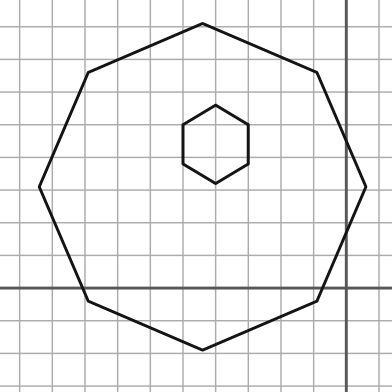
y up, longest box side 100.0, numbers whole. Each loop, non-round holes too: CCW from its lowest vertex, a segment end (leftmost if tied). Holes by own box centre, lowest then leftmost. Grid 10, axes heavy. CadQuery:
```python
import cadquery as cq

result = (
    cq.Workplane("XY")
    .moveTo(-44.0, -19.0)
    .lineTo(-9.0, -4.0)
    .lineTo(6.0, 31.0)
    .lineTo(-9.0, 66.0)
    .lineTo(-44.0, 81.0)
    .lineTo(-79.0, 66.0)
    .lineTo(-94.0, 31.0)
    .lineTo(-79.0, -4.0)
    .close()
    .moveTo(-40.0, 32.0)
    .lineTo(-30.0, 38.0)
    .lineTo(-30.0, 50.0)
    .lineTo(-40.0, 56.0)
    .lineTo(-50.0, 50.0)
    .lineTo(-50.0, 38.0)
    .close()
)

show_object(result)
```